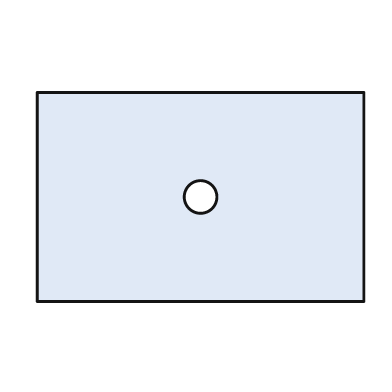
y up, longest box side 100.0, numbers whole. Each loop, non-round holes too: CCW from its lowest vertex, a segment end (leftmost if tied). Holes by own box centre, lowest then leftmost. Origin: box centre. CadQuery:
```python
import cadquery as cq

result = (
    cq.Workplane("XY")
    .moveTo(-50.0, -32.0)
    .lineTo(50.0, -32.0)
    .lineTo(50.0, 32.0)
    .lineTo(-50.0, 32.0)
    .close()
    .moveTo(0.0, 0.0)
    .circle(5.0)
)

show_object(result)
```